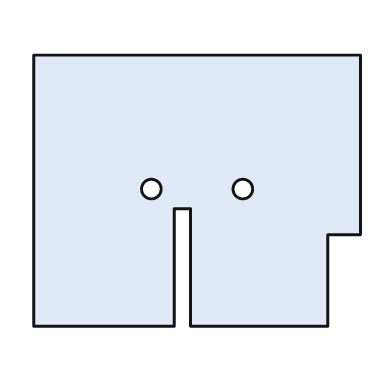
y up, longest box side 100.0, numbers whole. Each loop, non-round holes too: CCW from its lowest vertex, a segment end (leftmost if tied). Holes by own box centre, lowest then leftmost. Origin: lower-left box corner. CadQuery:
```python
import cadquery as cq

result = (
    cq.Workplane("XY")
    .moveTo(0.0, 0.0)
    .lineTo(43.0, 0.0)
    .lineTo(43.0, 36.0)
    .lineTo(48.0, 36.0)
    .lineTo(48.0, 0.0)
    .lineTo(90.0, 0.0)
    .lineTo(90.0, 28.0)
    .lineTo(100.0, 28.0)
    .lineTo(100.0, 83.0)
    .lineTo(0.0, 83.0)
    .close()
    .moveTo(36.0, 42.0)
    .circle(3.0)
    .moveTo(64.0, 42.0)
    .circle(3.0)
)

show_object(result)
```